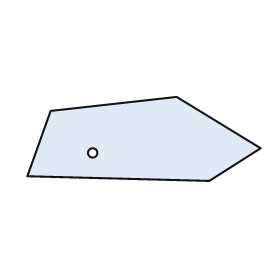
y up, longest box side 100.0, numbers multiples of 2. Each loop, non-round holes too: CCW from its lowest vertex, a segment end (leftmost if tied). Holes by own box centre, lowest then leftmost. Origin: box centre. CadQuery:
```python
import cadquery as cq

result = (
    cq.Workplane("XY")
    .moveTo(28.0, -18.0)
    .lineTo(50.0, -4.0)
    .lineTo(14.0, 18.0)
    .lineTo(-40.0, 12.0)
    .lineTo(-50.0, -16.0)
    .close()
    .moveTo(-22.0, -6.0)
    .circle(2.0)
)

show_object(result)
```